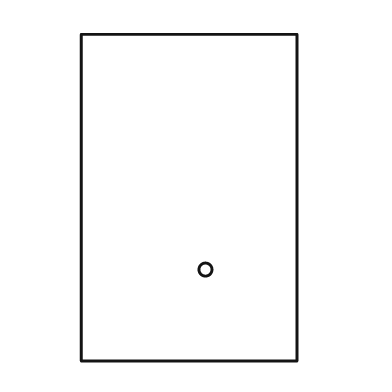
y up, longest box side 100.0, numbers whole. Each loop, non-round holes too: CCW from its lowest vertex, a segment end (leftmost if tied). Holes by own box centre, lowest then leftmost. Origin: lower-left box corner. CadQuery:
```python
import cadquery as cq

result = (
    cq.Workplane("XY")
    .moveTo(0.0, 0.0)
    .lineTo(66.0, 0.0)
    .lineTo(66.0, 100.0)
    .lineTo(0.0, 100.0)
    .close()
    .moveTo(38.0, 28.0)
    .circle(2.0)
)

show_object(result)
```